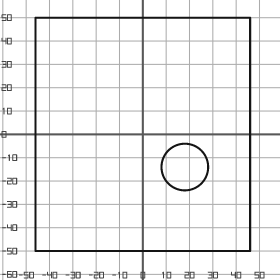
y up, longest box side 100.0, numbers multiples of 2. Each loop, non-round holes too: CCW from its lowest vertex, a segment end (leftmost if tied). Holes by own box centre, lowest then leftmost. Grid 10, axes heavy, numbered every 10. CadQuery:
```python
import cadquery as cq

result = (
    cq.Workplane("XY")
    .moveTo(-46.0, -50.0)
    .lineTo(46.0, -50.0)
    .lineTo(46.0, 50.0)
    .lineTo(-46.0, 50.0)
    .close()
    .moveTo(18.0, -14.0)
    .circle(10.0)
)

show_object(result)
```